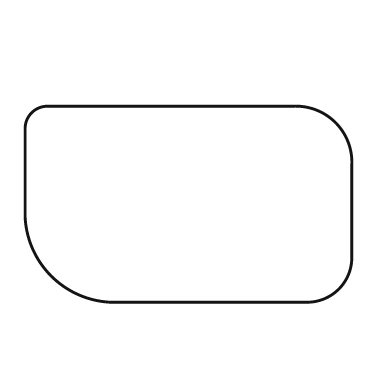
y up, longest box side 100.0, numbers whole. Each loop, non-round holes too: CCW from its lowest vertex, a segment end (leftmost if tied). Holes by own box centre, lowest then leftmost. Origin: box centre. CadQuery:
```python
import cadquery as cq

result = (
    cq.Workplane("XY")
    .moveTo(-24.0, -30.0)
    .lineTo(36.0, -30.0)
    .threePointArc((46.0, -26.0), (50.0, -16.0))
    .lineTo(50.0, 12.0)
    .threePointArc((45.0, 25.0), (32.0, 30.0))
    .lineTo(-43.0, 30.0)
    .threePointArc((-48.0, 28.0), (-50.0, 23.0))
    .lineTo(-50.0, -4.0)
    .threePointArc((-42.0, -22.0), (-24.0, -30.0))
    .close()
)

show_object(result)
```